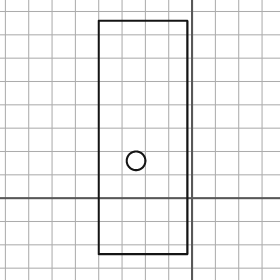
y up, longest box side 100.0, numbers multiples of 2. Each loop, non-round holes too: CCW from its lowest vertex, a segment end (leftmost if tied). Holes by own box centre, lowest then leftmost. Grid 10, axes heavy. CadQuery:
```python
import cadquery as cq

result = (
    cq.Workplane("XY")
    .moveTo(-40.0, -24.0)
    .lineTo(-2.0, -24.0)
    .lineTo(-2.0, 76.0)
    .lineTo(-40.0, 76.0)
    .close()
    .moveTo(-24.0, 16.0)
    .circle(4.0)
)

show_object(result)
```